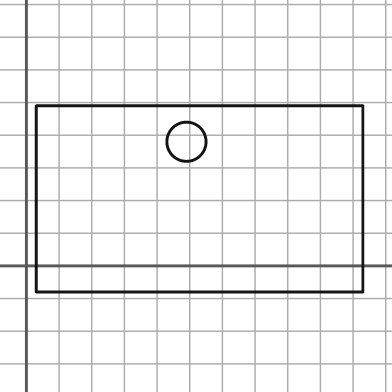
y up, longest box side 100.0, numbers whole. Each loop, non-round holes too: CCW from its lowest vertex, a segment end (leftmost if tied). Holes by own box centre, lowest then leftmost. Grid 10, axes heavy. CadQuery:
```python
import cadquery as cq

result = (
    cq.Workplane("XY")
    .moveTo(3.0, -8.0)
    .lineTo(103.0, -8.0)
    .lineTo(103.0, 49.0)
    .lineTo(3.0, 49.0)
    .close()
    .moveTo(49.0, 38.0)
    .circle(6.0)
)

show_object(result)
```